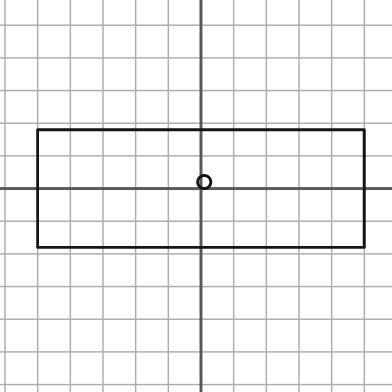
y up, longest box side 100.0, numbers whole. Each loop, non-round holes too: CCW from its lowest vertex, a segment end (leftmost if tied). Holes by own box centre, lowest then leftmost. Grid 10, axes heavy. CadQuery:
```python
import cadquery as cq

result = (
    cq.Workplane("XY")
    .moveTo(-50.0, -18.0)
    .lineTo(50.0, -18.0)
    .lineTo(50.0, 18.0)
    .lineTo(-50.0, 18.0)
    .close()
    .moveTo(1.0, 2.0)
    .circle(2.0)
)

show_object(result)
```